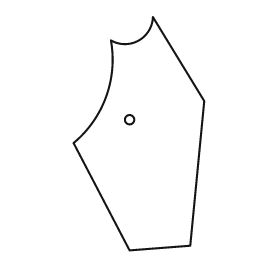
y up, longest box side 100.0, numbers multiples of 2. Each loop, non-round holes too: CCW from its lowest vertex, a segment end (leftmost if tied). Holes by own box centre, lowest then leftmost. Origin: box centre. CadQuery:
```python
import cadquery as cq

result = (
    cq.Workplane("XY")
    .moveTo(-4.0, -50.0)
    .lineTo(22.0, -48.0)
    .lineTo(28.0, 14.0)
    .lineTo(6.0, 50.0)
    .threePointArc((0.0, 40.0), (-12.0, 40.0))
    .threePointArc((-14.0, 16.0), (-28.0, -4.0))
    .close()
    .moveTo(-4.0, 6.0)
    .circle(2.0)
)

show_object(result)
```